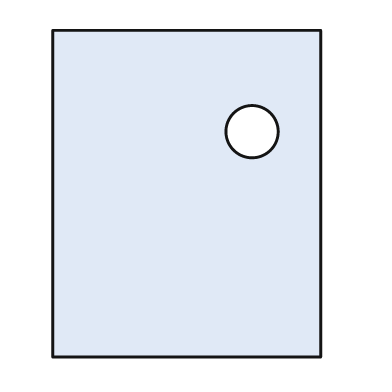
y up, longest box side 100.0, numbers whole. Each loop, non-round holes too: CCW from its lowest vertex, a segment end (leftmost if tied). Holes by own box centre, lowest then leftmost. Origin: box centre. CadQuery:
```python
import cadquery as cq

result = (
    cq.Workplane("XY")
    .moveTo(-41.0, -50.0)
    .lineTo(41.0, -50.0)
    .lineTo(41.0, 50.0)
    .lineTo(-41.0, 50.0)
    .close()
    .moveTo(20.0, 19.0)
    .circle(8.0)
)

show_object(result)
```